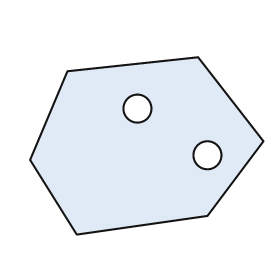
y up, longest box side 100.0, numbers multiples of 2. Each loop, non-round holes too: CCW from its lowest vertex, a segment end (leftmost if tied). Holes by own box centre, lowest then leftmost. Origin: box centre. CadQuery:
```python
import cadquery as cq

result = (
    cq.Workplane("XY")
    .moveTo(-30.0, -38.0)
    .lineTo(26.0, -30.0)
    .lineTo(50.0, 2.0)
    .lineTo(22.0, 38.0)
    .lineTo(-34.0, 32.0)
    .lineTo(-50.0, -6.0)
    .close()
    .moveTo(26.0, -4.0)
    .circle(6.0)
    .moveTo(-4.0, 16.0)
    .circle(6.0)
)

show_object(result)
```